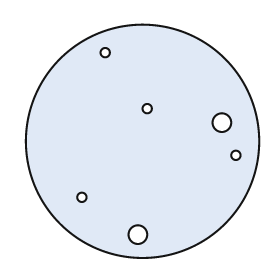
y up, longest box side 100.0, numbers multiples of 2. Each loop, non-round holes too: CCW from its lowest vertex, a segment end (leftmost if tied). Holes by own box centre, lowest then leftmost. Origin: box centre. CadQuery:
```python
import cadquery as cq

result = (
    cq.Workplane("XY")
    .moveTo(0.0, 0.0)
    .circle(50.0)
    .moveTo(-2.0, -40.0)
    .circle(4.0)
    .moveTo(-26.0, -24.0)
    .circle(2.0)
    .moveTo(40.0, -6.0)
    .circle(2.0)
    .moveTo(34.0, 8.0)
    .circle(4.0)
    .moveTo(2.0, 14.0)
    .circle(2.0)
    .moveTo(-16.0, 38.0)
    .circle(2.0)
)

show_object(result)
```